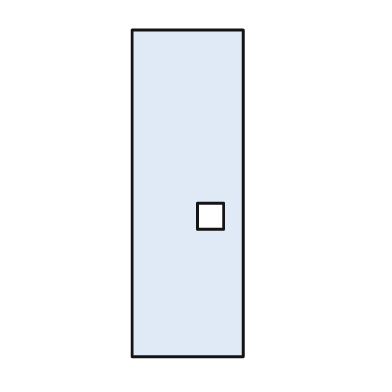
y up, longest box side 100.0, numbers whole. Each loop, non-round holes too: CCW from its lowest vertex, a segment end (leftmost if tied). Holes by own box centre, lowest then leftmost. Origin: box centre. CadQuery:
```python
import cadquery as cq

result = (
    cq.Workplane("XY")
    .moveTo(-17.0, -50.0)
    .lineTo(17.0, -50.0)
    .lineTo(17.0, 50.0)
    .lineTo(-17.0, 50.0)
    .close()
    .moveTo(3.0, -11.0)
    .lineTo(11.0, -11.0)
    .lineTo(11.0, -3.0)
    .lineTo(3.0, -3.0)
    .close()
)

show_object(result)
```